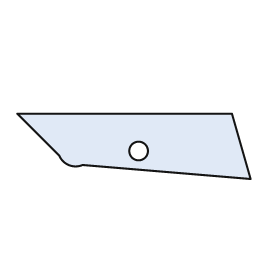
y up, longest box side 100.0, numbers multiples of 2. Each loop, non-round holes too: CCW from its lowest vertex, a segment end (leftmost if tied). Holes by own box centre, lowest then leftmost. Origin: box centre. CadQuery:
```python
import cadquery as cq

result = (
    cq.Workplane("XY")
    .moveTo(50.0, -14.0)
    .lineTo(42.0, 14.0)
    .lineTo(-50.0, 14.0)
    .lineTo(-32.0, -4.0)
    .threePointArc((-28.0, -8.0), (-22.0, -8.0))
    .close()
    .moveTo(2.0, -2.0)
    .circle(4.0)
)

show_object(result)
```